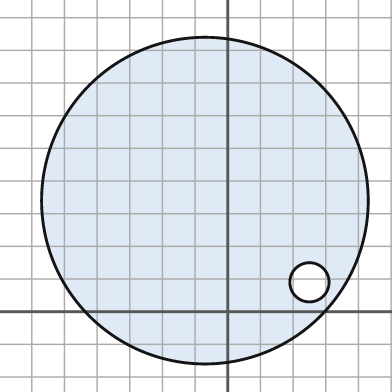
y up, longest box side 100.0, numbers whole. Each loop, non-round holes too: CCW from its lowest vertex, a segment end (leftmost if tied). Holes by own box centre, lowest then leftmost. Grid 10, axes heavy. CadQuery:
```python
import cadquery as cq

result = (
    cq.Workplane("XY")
    .moveTo(-7.0, 34.0)
    .circle(50.0)
    .moveTo(25.0, 9.0)
    .circle(6.0)
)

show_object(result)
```